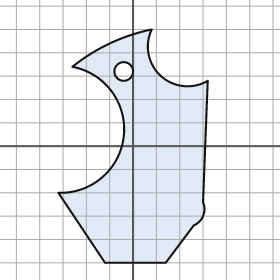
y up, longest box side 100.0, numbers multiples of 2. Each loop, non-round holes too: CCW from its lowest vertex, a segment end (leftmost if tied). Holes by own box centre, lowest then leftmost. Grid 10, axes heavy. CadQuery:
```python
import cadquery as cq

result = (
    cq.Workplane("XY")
    .moveTo(-12.0, -50.0)
    .lineTo(14.0, -50.0)
    .lineTo(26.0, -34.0)
    .threePointArc((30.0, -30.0), (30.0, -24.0))
    .lineTo(32.0, 28.0)
    .threePointArc((12.0, 30.0), (8.0, 50.0))
    .threePointArc((-10.0, 44.0), (-26.0, 34.0))
    .threePointArc((-4.0, 4.0), (-32.0, -20.0))
    .close()
    .moveTo(-4.0, 32.0)
    .circle(4.0)
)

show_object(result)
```